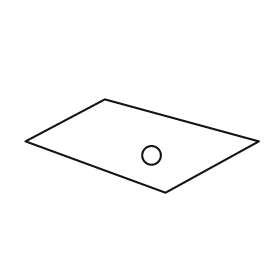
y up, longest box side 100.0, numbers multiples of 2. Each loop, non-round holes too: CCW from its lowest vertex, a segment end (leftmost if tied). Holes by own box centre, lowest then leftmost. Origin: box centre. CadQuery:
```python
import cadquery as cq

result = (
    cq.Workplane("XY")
    .moveTo(10.0, -20.0)
    .lineTo(50.0, 2.0)
    .lineTo(-16.0, 20.0)
    .lineTo(-50.0, 2.0)
    .close()
    .moveTo(4.0, -4.0)
    .circle(4.0)
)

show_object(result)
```